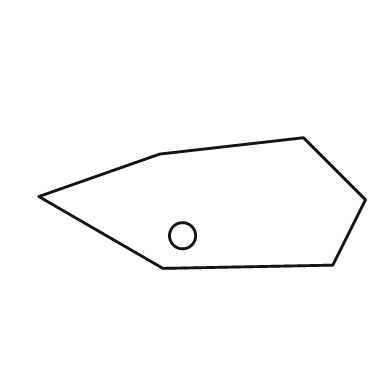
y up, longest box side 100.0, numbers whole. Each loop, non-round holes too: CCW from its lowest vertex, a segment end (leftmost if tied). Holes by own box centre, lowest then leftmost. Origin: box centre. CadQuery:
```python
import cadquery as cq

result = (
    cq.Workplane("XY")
    .moveTo(-12.0, -20.0)
    .lineTo(40.0, -19.0)
    .lineTo(50.0, 1.0)
    .lineTo(31.0, 20.0)
    .lineTo(-13.0, 15.0)
    .lineTo(-50.0, 2.0)
    .close()
    .moveTo(-6.0, -10.0)
    .circle(4.0)
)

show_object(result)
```